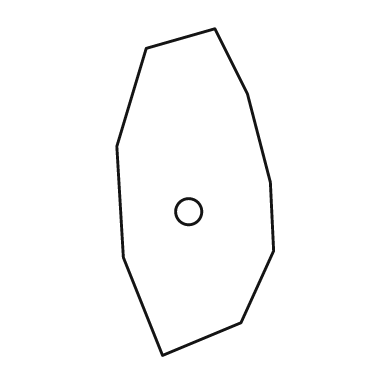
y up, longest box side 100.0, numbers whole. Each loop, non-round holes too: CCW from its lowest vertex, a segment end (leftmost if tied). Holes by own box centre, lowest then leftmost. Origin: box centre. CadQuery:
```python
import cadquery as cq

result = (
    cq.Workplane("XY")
    .moveTo(-10.0, -50.0)
    .lineTo(14.0, -40.0)
    .lineTo(24.0, -18.0)
    .lineTo(23.0, 3.0)
    .lineTo(16.0, 30.0)
    .lineTo(6.0, 50.0)
    .lineTo(-15.0, 44.0)
    .lineTo(-24.0, 14.0)
    .lineTo(-22.0, -20.0)
    .close()
    .moveTo(-2.0, -6.0)
    .circle(4.0)
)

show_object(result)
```